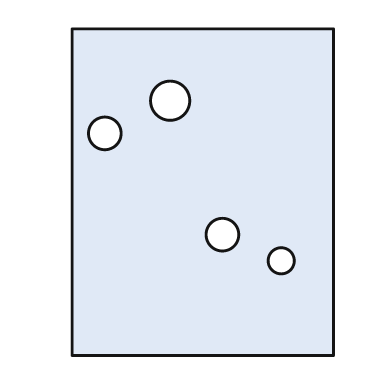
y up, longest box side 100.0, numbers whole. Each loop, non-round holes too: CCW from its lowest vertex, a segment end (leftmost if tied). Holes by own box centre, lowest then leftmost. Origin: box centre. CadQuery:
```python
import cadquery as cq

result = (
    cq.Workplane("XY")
    .moveTo(-40.0, -50.0)
    .lineTo(40.0, -50.0)
    .lineTo(40.0, 50.0)
    .lineTo(-40.0, 50.0)
    .close()
    .moveTo(24.0, -21.0)
    .circle(4.0)
    .moveTo(6.0, -13.0)
    .circle(5.0)
    .moveTo(-30.0, 18.0)
    .circle(5.0)
    .moveTo(-10.0, 28.0)
    .circle(6.0)
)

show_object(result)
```